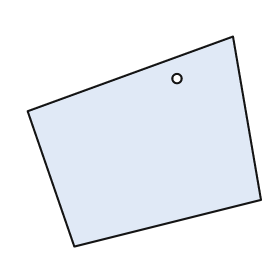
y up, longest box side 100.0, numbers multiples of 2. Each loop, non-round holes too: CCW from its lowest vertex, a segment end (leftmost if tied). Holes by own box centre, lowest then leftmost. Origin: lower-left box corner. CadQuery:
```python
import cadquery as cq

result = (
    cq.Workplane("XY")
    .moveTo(20.0, 0.0)
    .lineTo(100.0, 20.0)
    .lineTo(88.0, 90.0)
    .lineTo(0.0, 58.0)
    .close()
    .moveTo(64.0, 72.0)
    .circle(2.0)
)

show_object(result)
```